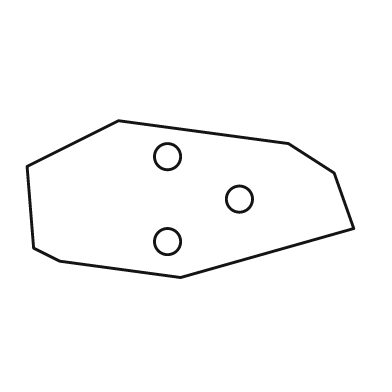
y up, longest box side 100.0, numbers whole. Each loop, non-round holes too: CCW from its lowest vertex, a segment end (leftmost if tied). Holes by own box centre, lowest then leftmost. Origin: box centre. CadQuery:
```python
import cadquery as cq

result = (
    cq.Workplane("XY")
    .moveTo(-3.0, -24.0)
    .lineTo(50.0, -9.0)
    .lineTo(44.0, 8.0)
    .lineTo(30.0, 17.0)
    .lineTo(-22.0, 24.0)
    .lineTo(-50.0, 10.0)
    .lineTo(-48.0, -15.0)
    .lineTo(-40.0, -19.0)
    .close()
    .moveTo(-7.0, -13.0)
    .circle(4.0)
    .moveTo(15.0, 0.0)
    .circle(4.0)
    .moveTo(-7.0, 13.0)
    .circle(4.0)
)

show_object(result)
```